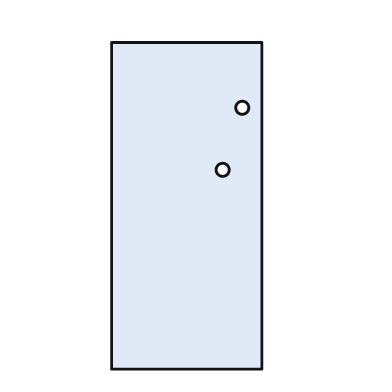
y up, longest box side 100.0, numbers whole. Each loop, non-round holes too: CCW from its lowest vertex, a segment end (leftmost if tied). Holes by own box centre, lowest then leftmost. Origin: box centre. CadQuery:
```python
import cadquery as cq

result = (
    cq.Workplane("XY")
    .moveTo(-23.0, -50.0)
    .lineTo(23.0, -50.0)
    .lineTo(23.0, 50.0)
    .lineTo(-23.0, 50.0)
    .close()
    .moveTo(11.0, 11.0)
    .circle(2.0)
    .moveTo(17.0, 30.0)
    .circle(2.0)
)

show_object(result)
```